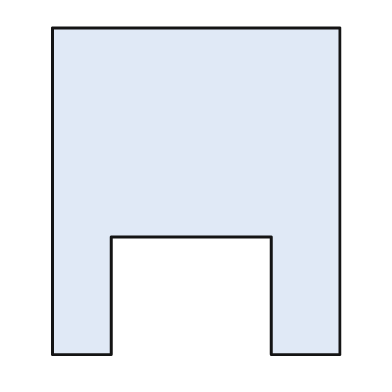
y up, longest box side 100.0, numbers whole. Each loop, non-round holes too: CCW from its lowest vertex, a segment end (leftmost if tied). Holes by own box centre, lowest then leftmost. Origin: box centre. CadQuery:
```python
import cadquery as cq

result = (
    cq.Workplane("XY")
    .moveTo(-44.0, -50.0)
    .lineTo(-26.0, -50.0)
    .lineTo(-26.0, -14.0)
    .lineTo(23.0, -14.0)
    .lineTo(23.0, -50.0)
    .lineTo(44.0, -50.0)
    .lineTo(44.0, 50.0)
    .lineTo(-44.0, 50.0)
    .close()
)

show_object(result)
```